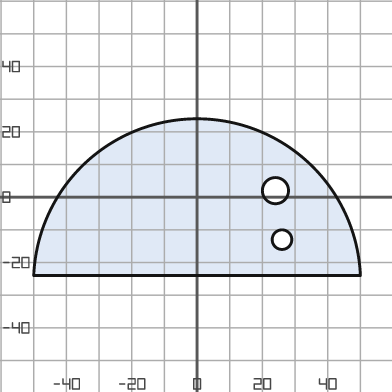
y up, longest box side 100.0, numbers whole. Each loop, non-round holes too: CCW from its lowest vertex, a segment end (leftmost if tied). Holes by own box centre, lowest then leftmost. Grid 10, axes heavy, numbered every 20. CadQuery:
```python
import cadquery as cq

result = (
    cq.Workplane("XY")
    .moveTo(-50.0, -24.0)
    .lineTo(50.0, -24.0)
    .threePointArc((0.0, 24.0), (-50.0, -24.0))
    .close()
    .moveTo(26.0, -13.0)
    .circle(3.0)
    .moveTo(24.0, 2.0)
    .circle(4.0)
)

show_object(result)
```